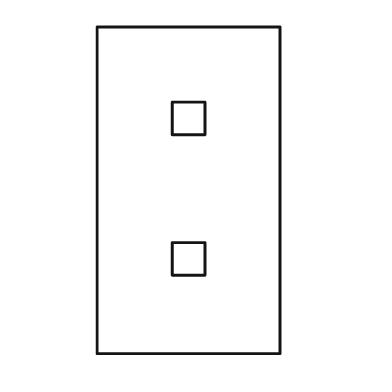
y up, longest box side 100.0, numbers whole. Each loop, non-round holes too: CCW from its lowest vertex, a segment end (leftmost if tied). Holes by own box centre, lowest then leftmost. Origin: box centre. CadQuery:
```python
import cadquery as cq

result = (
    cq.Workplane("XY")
    .moveTo(-28.0, -50.0)
    .lineTo(28.0, -50.0)
    .lineTo(28.0, 50.0)
    .lineTo(-28.0, 50.0)
    .close()
    .moveTo(-5.0, -26.0)
    .lineTo(5.0, -26.0)
    .lineTo(5.0, -16.0)
    .lineTo(-5.0, -16.0)
    .close()
    .moveTo(-5.0, 17.0)
    .lineTo(5.0, 17.0)
    .lineTo(5.0, 27.0)
    .lineTo(-5.0, 27.0)
    .close()
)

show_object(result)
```